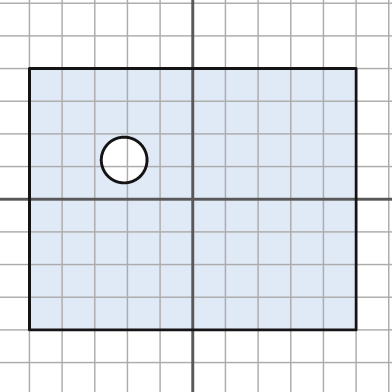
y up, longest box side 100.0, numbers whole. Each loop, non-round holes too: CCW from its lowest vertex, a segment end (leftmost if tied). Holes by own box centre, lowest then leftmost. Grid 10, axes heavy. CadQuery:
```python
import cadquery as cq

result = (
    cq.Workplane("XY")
    .moveTo(-50.0, -40.0)
    .lineTo(50.0, -40.0)
    .lineTo(50.0, 40.0)
    .lineTo(-50.0, 40.0)
    .close()
    .moveTo(-21.0, 12.0)
    .circle(7.0)
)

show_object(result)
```